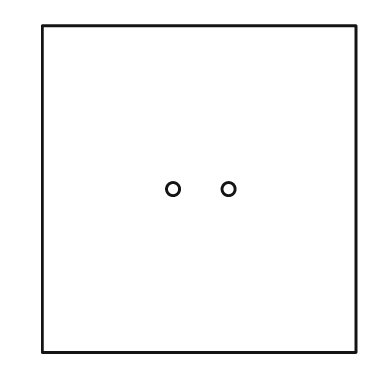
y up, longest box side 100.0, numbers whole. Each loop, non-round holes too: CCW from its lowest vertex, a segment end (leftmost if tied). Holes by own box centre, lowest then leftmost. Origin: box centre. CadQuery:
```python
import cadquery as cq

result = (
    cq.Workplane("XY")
    .moveTo(-48.0, -50.0)
    .lineTo(48.0, -50.0)
    .lineTo(48.0, 50.0)
    .lineTo(-48.0, 50.0)
    .close()
    .moveTo(-8.0, 0.0)
    .circle(2.0)
    .moveTo(9.0, 0.0)
    .circle(2.0)
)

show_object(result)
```